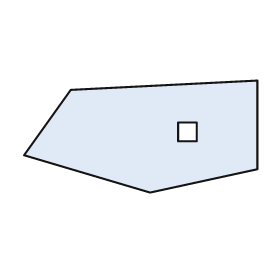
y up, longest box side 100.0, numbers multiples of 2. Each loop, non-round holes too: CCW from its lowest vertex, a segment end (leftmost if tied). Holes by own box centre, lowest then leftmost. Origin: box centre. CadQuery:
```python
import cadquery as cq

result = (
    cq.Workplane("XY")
    .moveTo(4.0, -24.0)
    .lineTo(50.0, -14.0)
    .lineTo(50.0, 24.0)
    .lineTo(-30.0, 20.0)
    .lineTo(-50.0, -8.0)
    .close()
    .moveTo(16.0, -2.0)
    .lineTo(24.0, -2.0)
    .lineTo(24.0, 6.0)
    .lineTo(16.0, 6.0)
    .close()
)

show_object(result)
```